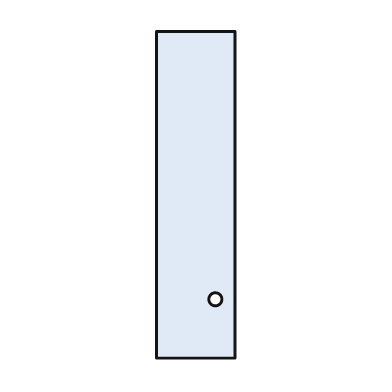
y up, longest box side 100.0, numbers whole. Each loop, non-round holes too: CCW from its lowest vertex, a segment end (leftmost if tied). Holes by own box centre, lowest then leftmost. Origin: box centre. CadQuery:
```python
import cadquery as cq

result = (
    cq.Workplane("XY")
    .moveTo(-12.0, -50.0)
    .lineTo(12.0, -50.0)
    .lineTo(12.0, 50.0)
    .lineTo(-12.0, 50.0)
    .close()
    .moveTo(6.0, -32.0)
    .circle(2.0)
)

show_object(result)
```